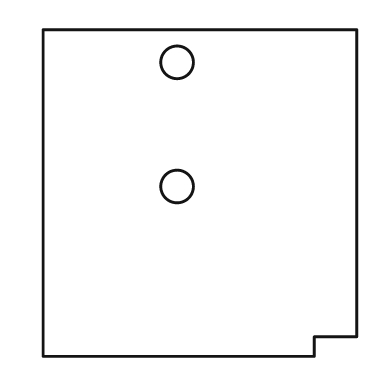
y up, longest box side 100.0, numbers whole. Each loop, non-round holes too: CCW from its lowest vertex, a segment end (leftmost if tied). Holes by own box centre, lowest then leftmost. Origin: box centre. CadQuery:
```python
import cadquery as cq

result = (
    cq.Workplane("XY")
    .moveTo(-48.0, -50.0)
    .lineTo(35.0, -50.0)
    .lineTo(35.0, -44.0)
    .lineTo(48.0, -44.0)
    .lineTo(48.0, 50.0)
    .lineTo(-48.0, 50.0)
    .close()
    .moveTo(-7.0, 2.0)
    .circle(5.0)
    .moveTo(-7.0, 40.0)
    .circle(5.0)
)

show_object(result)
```